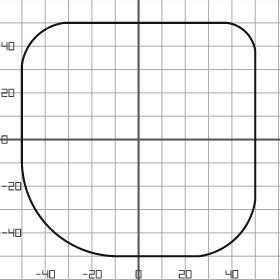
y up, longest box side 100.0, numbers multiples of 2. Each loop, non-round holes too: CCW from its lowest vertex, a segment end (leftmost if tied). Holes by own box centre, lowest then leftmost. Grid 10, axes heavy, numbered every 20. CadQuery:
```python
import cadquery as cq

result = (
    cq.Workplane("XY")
    .moveTo(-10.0, -50.0)
    .lineTo(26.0, -50.0)
    .threePointArc((42.0, -42.0), (50.0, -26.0))
    .lineTo(50.0, 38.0)
    .threePointArc((46.0, 46.0), (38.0, 50.0))
    .lineTo(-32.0, 50.0)
    .threePointArc((-44.0, 44.0), (-50.0, 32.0))
    .lineTo(-50.0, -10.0)
    .threePointArc((-38.0, -38.0), (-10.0, -50.0))
    .close()
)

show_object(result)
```